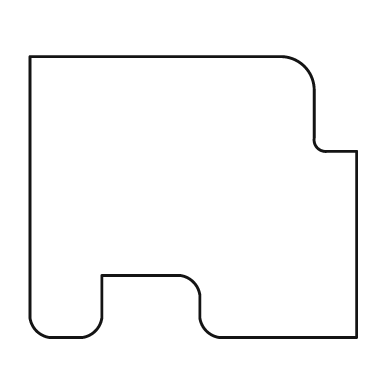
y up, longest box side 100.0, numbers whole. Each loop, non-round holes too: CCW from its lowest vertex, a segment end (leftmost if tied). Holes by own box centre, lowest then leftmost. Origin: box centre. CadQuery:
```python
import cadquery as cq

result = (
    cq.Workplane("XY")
    .moveTo(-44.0, -43.0)
    .lineTo(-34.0, -43.0)
    .threePointArc((-30.0, -41.0), (-28.0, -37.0))
    .lineTo(-28.0, -24.0)
    .lineTo(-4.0, -24.0)
    .threePointArc((0.0, -26.0), (2.0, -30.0))
    .lineTo(2.0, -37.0)
    .threePointArc((4.0, -41.0), (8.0, -43.0))
    .lineTo(50.0, -43.0)
    .lineTo(50.0, 14.0)
    .lineTo(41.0, 14.0)
    .threePointArc((38.0, 15.0), (37.0, 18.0))
    .lineTo(37.0, 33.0)
    .threePointArc((34.0, 40.0), (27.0, 43.0))
    .lineTo(-50.0, 43.0)
    .lineTo(-50.0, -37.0)
    .threePointArc((-48.0, -41.0), (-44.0, -43.0))
    .close()
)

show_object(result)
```